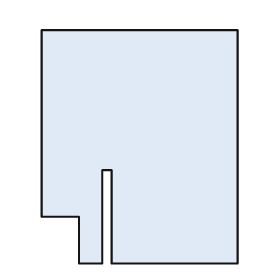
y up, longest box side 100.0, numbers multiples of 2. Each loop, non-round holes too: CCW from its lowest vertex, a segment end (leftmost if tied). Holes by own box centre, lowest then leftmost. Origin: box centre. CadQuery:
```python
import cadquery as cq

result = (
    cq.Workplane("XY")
    .moveTo(-26.0, -50.0)
    .lineTo(-16.0, -50.0)
    .lineTo(-16.0, -10.0)
    .lineTo(-12.0, -10.0)
    .lineTo(-12.0, -50.0)
    .lineTo(42.0, -50.0)
    .lineTo(42.0, 50.0)
    .lineTo(-42.0, 50.0)
    .lineTo(-42.0, -30.0)
    .lineTo(-26.0, -30.0)
    .close()
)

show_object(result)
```